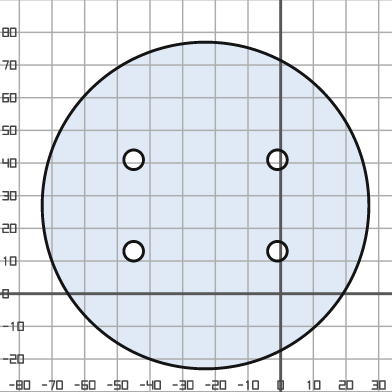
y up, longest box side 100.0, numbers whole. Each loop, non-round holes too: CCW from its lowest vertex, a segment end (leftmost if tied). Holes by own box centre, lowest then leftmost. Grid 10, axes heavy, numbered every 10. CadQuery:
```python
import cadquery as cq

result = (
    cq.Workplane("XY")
    .moveTo(-23.0, 27.0)
    .circle(50.0)
    .moveTo(-45.0, 13.0)
    .circle(3.0)
    .moveTo(-1.0, 13.0)
    .circle(3.0)
    .moveTo(-45.0, 41.0)
    .circle(3.0)
    .moveTo(-1.0, 41.0)
    .circle(3.0)
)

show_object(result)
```